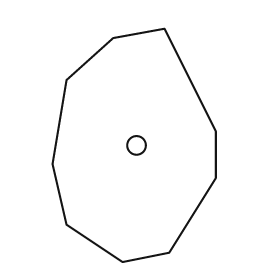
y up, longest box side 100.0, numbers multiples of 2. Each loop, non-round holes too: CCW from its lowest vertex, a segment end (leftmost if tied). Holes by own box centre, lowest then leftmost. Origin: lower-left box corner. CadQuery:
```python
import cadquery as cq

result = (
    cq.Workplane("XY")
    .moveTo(30.0, 0.0)
    .lineTo(50.0, 4.0)
    .lineTo(70.0, 36.0)
    .lineTo(70.0, 56.0)
    .lineTo(48.0, 100.0)
    .lineTo(26.0, 96.0)
    .lineTo(6.0, 78.0)
    .lineTo(0.0, 42.0)
    .lineTo(6.0, 16.0)
    .close()
    .moveTo(36.0, 50.0)
    .circle(4.0)
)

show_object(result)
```